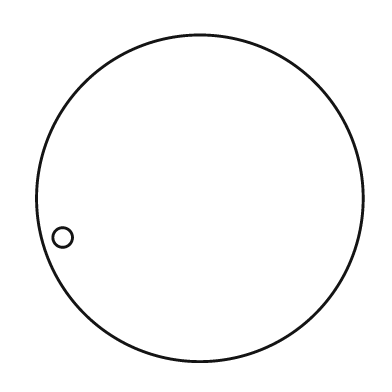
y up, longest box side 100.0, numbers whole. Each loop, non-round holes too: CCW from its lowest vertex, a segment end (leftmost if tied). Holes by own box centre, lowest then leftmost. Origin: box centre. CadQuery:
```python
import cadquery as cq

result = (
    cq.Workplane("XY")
    .moveTo(0.0, 0.0)
    .circle(50.0)
    .moveTo(-42.0, -12.0)
    .circle(3.0)
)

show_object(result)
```